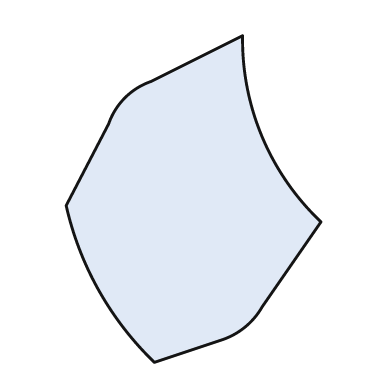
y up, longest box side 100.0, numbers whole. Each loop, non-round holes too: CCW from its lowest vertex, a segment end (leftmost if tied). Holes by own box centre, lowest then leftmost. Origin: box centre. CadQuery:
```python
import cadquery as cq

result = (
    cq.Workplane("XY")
    .moveTo(-12.0, -50.0)
    .lineTo(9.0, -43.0)
    .threePointArc((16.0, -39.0), (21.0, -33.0))
    .lineTo(39.0, -7.0)
    .threePointArc((21.0, 19.0), (15.0, 50.0))
    .lineTo(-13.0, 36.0)
    .threePointArc((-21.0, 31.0), (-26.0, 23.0))
    .lineTo(-39.0, -2.0)
    .threePointArc((-29.0, -28.0), (-12.0, -50.0))
    .close()
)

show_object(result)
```